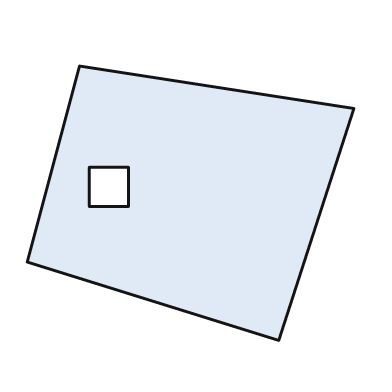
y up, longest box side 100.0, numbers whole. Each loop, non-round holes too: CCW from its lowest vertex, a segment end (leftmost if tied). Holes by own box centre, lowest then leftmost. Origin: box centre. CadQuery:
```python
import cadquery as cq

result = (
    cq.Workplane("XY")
    .moveTo(27.0, -42.0)
    .lineTo(50.0, 29.0)
    .lineTo(-34.0, 42.0)
    .lineTo(-50.0, -18.0)
    .close()
    .moveTo(-31.0, -1.0)
    .lineTo(-19.0, -1.0)
    .lineTo(-19.0, 11.0)
    .lineTo(-31.0, 11.0)
    .close()
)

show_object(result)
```